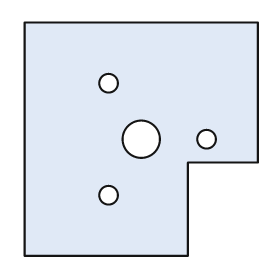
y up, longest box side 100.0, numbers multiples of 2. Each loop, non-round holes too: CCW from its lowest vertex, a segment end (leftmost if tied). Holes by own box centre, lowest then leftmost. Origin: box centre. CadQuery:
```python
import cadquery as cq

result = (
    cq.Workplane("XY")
    .moveTo(-50.0, -50.0)
    .lineTo(20.0, -50.0)
    .lineTo(20.0, -10.0)
    .lineTo(50.0, -10.0)
    .lineTo(50.0, 50.0)
    .lineTo(-50.0, 50.0)
    .close()
    .moveTo(-14.0, -24.0)
    .circle(4.0)
    .moveTo(0.0, 0.0)
    .circle(8.0)
    .moveTo(28.0, 0.0)
    .circle(4.0)
    .moveTo(-14.0, 24.0)
    .circle(4.0)
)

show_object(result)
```